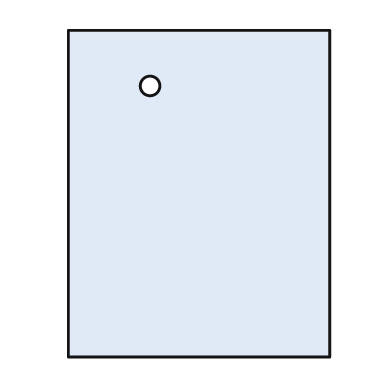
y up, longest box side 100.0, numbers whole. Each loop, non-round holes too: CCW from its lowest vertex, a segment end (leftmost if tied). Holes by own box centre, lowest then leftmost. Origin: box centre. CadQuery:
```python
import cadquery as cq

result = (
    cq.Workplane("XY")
    .moveTo(-40.0, -50.0)
    .lineTo(40.0, -50.0)
    .lineTo(40.0, 50.0)
    .lineTo(-40.0, 50.0)
    .close()
    .moveTo(-15.0, 33.0)
    .circle(3.0)
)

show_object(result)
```